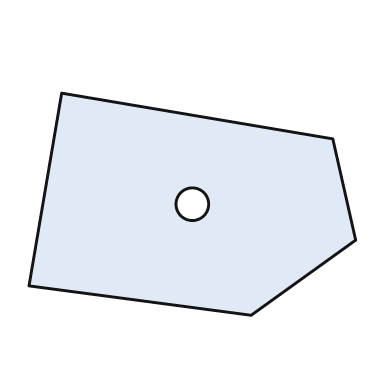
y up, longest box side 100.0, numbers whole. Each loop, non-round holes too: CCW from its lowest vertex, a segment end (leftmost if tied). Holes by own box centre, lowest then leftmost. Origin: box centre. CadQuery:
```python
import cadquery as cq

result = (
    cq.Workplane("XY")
    .moveTo(18.0, -34.0)
    .lineTo(50.0, -11.0)
    .lineTo(43.0, 20.0)
    .lineTo(-40.0, 34.0)
    .lineTo(-50.0, -25.0)
    .close()
    .moveTo(0.0, 0.0)
    .circle(5.0)
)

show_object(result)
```